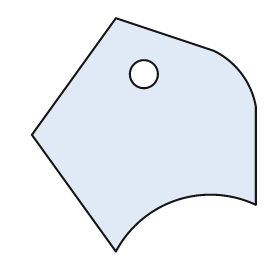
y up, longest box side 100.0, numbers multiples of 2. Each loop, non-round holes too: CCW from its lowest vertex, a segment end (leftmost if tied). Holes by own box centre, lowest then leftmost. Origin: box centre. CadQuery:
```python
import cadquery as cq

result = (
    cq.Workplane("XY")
    .moveTo(-12.0, -50.0)
    .threePointArc((14.0, -28.0), (48.0, -30.0))
    .lineTo(48.0, 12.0)
    .threePointArc((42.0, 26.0), (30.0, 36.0))
    .lineTo(-12.0, 50.0)
    .lineTo(-48.0, 0.0)
    .close()
    .moveTo(0.0, 26.0)
    .circle(6.0)
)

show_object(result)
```